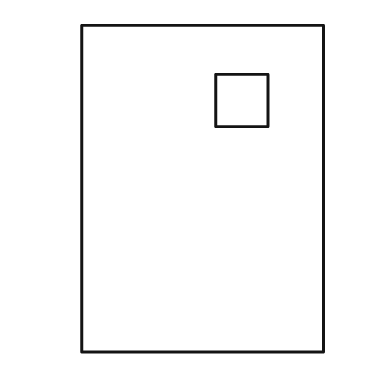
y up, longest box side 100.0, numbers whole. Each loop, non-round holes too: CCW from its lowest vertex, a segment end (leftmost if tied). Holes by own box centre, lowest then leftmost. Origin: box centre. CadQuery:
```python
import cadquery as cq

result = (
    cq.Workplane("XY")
    .moveTo(-37.0, -50.0)
    .lineTo(37.0, -50.0)
    .lineTo(37.0, 50.0)
    .lineTo(-37.0, 50.0)
    .close()
    .moveTo(4.0, 19.0)
    .lineTo(20.0, 19.0)
    .lineTo(20.0, 35.0)
    .lineTo(4.0, 35.0)
    .close()
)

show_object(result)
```